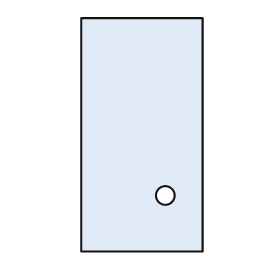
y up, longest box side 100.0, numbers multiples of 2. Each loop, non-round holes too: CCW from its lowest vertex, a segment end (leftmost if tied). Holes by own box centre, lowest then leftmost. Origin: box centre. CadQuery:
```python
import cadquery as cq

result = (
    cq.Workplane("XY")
    .moveTo(-26.0, -50.0)
    .lineTo(26.0, -50.0)
    .lineTo(26.0, 50.0)
    .lineTo(-26.0, 50.0)
    .close()
    .moveTo(10.0, -26.0)
    .circle(4.0)
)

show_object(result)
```